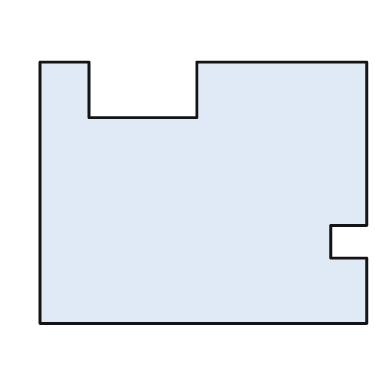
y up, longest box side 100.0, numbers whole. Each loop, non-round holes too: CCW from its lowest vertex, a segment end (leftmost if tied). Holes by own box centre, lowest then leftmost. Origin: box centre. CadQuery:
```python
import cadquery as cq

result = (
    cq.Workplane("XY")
    .moveTo(-50.0, -40.0)
    .lineTo(50.0, -40.0)
    .lineTo(50.0, -20.0)
    .lineTo(39.0, -20.0)
    .lineTo(39.0, -10.0)
    .lineTo(50.0, -10.0)
    .lineTo(50.0, 40.0)
    .lineTo(-2.0, 40.0)
    .lineTo(-2.0, 23.0)
    .lineTo(-35.0, 23.0)
    .lineTo(-35.0, 40.0)
    .lineTo(-50.0, 40.0)
    .close()
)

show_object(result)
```